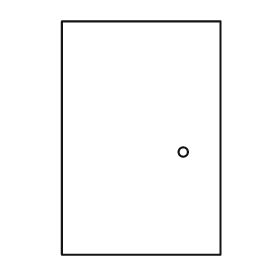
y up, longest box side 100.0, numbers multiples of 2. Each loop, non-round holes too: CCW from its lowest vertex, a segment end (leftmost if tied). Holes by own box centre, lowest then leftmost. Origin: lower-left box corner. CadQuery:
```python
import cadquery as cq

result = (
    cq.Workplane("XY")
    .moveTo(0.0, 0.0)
    .lineTo(68.0, 0.0)
    .lineTo(68.0, 100.0)
    .lineTo(0.0, 100.0)
    .close()
    .moveTo(52.0, 44.0)
    .circle(2.0)
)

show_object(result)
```